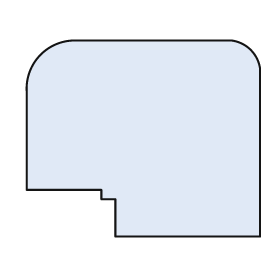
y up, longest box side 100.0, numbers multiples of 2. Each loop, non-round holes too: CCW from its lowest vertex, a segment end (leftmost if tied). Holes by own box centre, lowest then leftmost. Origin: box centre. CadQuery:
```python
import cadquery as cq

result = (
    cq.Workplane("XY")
    .moveTo(-12.0, -42.0)
    .lineTo(50.0, -42.0)
    .lineTo(50.0, 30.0)
    .threePointArc((46.0, 38.0), (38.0, 42.0))
    .lineTo(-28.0, 42.0)
    .threePointArc((-44.0, 36.0), (-50.0, 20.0))
    .lineTo(-50.0, -22.0)
    .lineTo(-18.0, -22.0)
    .lineTo(-18.0, -26.0)
    .lineTo(-12.0, -26.0)
    .close()
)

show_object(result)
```